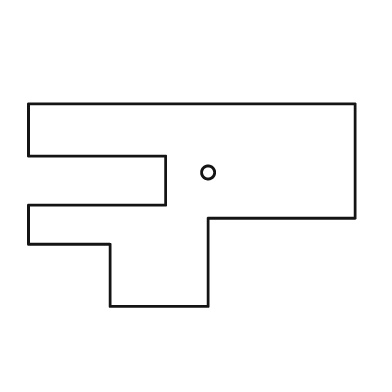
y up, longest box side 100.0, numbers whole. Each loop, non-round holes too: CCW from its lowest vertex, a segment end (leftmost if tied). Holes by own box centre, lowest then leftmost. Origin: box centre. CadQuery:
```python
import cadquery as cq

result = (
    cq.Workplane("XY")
    .moveTo(-25.0, -31.0)
    .lineTo(5.0, -31.0)
    .lineTo(5.0, -4.0)
    .lineTo(50.0, -4.0)
    .lineTo(50.0, 31.0)
    .lineTo(-50.0, 31.0)
    .lineTo(-50.0, 15.0)
    .lineTo(-8.0, 15.0)
    .lineTo(-8.0, 0.0)
    .lineTo(-50.0, 0.0)
    .lineTo(-50.0, -12.0)
    .lineTo(-25.0, -12.0)
    .close()
    .moveTo(5.0, 10.0)
    .circle(2.0)
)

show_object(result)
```